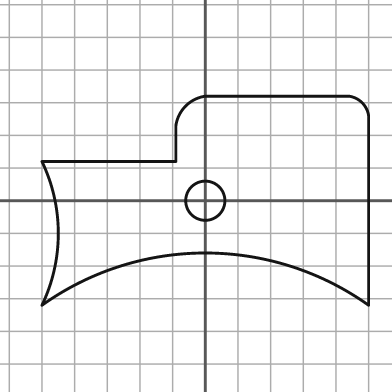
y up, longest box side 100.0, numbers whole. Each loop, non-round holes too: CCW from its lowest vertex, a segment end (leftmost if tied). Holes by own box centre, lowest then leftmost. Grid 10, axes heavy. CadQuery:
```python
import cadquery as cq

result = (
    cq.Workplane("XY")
    .moveTo(-50.0, -32.0)
    .threePointArc((0.0, -16.0), (50.0, -32.0))
    .lineTo(50.0, 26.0)
    .threePointArc((48.0, 30.0), (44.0, 32.0))
    .lineTo(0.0, 32.0)
    .threePointArc((-6.0, 29.0), (-9.0, 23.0))
    .lineTo(-9.0, 12.0)
    .lineTo(-50.0, 12.0)
    .threePointArc((-45.0, -10.0), (-50.0, -32.0))
    .close()
    .moveTo(0.0, 0.0)
    .circle(6.0)
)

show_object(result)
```